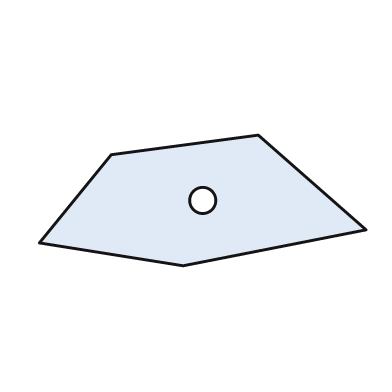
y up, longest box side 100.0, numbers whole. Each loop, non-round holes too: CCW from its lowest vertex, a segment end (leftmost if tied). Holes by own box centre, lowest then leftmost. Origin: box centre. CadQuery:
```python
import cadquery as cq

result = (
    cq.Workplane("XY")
    .moveTo(-6.0, -20.0)
    .lineTo(50.0, -9.0)
    .lineTo(17.0, 20.0)
    .lineTo(-28.0, 14.0)
    .lineTo(-50.0, -13.0)
    .close()
    .moveTo(0.0, 0.0)
    .circle(4.0)
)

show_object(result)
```